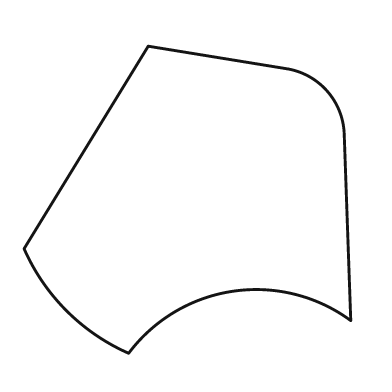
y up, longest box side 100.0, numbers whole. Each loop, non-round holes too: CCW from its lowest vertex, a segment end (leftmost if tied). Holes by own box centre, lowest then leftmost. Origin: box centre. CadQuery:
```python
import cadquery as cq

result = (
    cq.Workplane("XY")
    .moveTo(-18.0, -47.0)
    .threePointArc((14.0, -28.0), (50.0, -37.0))
    .lineTo(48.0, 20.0)
    .threePointArc((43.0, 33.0), (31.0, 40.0))
    .lineTo(-12.0, 47.0)
    .lineTo(-50.0, -15.0)
    .threePointArc((-37.0, -34.0), (-18.0, -47.0))
    .close()
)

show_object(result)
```